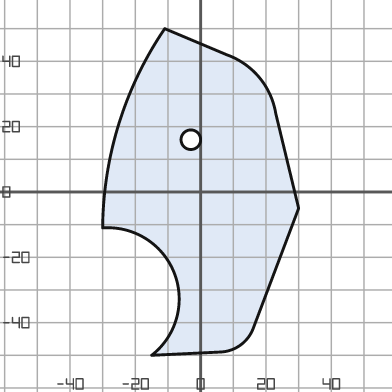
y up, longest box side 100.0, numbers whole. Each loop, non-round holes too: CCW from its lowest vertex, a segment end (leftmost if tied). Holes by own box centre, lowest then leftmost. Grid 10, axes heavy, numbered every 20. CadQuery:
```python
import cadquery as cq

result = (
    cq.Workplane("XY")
    .moveTo(-15.0, -50.0)
    .lineTo(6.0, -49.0)
    .threePointArc((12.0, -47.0), (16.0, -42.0))
    .lineTo(30.0, -5.0)
    .lineTo(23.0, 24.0)
    .threePointArc((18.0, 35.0), (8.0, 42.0))
    .lineTo(-11.0, 50.0)
    .threePointArc((-25.0, 21.0), (-30.0, -11.0))
    .threePointArc((-8.0, -25.0), (-15.0, -50.0))
    .close()
    .moveTo(-3.0, 16.0)
    .circle(3.0)
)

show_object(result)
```